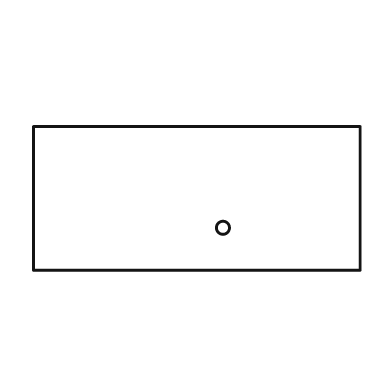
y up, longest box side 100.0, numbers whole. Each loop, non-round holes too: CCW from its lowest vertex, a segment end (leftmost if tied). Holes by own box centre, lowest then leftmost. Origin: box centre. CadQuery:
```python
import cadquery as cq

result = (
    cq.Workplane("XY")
    .moveTo(-50.0, -22.0)
    .lineTo(50.0, -22.0)
    .lineTo(50.0, 22.0)
    .lineTo(-50.0, 22.0)
    .close()
    .moveTo(8.0, -9.0)
    .circle(2.0)
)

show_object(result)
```